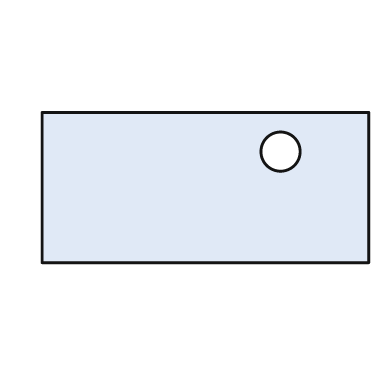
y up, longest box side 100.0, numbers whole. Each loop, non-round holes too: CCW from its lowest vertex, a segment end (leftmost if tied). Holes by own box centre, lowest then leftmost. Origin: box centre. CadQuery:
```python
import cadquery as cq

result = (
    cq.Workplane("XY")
    .moveTo(-50.0, -23.0)
    .lineTo(50.0, -23.0)
    .lineTo(50.0, 23.0)
    .lineTo(-50.0, 23.0)
    .close()
    .moveTo(23.0, 11.0)
    .circle(6.0)
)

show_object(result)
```